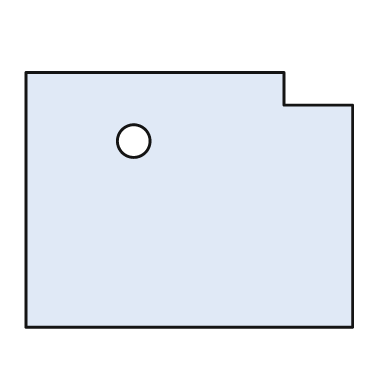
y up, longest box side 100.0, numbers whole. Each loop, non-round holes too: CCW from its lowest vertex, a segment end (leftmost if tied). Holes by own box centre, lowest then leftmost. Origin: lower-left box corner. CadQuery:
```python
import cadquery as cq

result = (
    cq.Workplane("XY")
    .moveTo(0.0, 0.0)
    .lineTo(100.0, 0.0)
    .lineTo(100.0, 68.0)
    .lineTo(79.0, 68.0)
    .lineTo(79.0, 78.0)
    .lineTo(0.0, 78.0)
    .close()
    .moveTo(33.0, 57.0)
    .circle(5.0)
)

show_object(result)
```